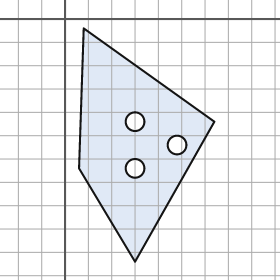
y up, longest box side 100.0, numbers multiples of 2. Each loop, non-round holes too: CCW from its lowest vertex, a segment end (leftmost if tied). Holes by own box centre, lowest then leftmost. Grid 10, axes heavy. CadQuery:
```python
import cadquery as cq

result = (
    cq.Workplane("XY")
    .moveTo(30.0, -104.0)
    .lineTo(64.0, -44.0)
    .lineTo(8.0, -4.0)
    .lineTo(6.0, -64.0)
    .close()
    .moveTo(30.0, -64.0)
    .circle(4.0)
    .moveTo(48.0, -54.0)
    .circle(4.0)
    .moveTo(30.0, -44.0)
    .circle(4.0)
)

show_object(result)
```